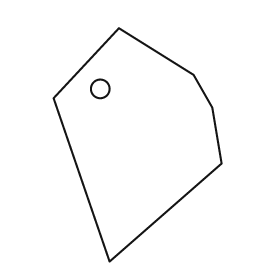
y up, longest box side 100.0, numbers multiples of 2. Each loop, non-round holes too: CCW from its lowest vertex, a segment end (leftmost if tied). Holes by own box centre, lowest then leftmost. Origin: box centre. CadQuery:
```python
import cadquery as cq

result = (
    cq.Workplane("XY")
    .moveTo(-12.0, -50.0)
    .lineTo(36.0, -8.0)
    .lineTo(32.0, 16.0)
    .lineTo(24.0, 30.0)
    .lineTo(-8.0, 50.0)
    .lineTo(-36.0, 20.0)
    .close()
    .moveTo(-16.0, 24.0)
    .circle(4.0)
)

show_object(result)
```